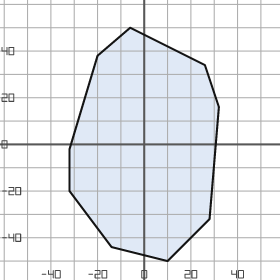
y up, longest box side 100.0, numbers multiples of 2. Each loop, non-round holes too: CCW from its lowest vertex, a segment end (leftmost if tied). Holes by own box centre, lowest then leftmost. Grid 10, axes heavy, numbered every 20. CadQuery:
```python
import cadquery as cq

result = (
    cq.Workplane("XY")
    .moveTo(10.0, -50.0)
    .lineTo(28.0, -32.0)
    .lineTo(32.0, 16.0)
    .lineTo(26.0, 34.0)
    .lineTo(-6.0, 50.0)
    .lineTo(-20.0, 38.0)
    .lineTo(-32.0, -2.0)
    .lineTo(-32.0, -20.0)
    .lineTo(-14.0, -44.0)
    .close()
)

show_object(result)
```